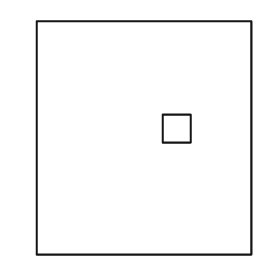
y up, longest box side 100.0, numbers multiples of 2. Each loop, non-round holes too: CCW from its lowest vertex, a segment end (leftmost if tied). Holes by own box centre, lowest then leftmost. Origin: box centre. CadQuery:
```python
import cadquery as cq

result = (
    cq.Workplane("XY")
    .moveTo(-46.0, -50.0)
    .lineTo(46.0, -50.0)
    .lineTo(46.0, 50.0)
    .lineTo(-46.0, 50.0)
    .close()
    .moveTo(8.0, -2.0)
    .lineTo(20.0, -2.0)
    .lineTo(20.0, 10.0)
    .lineTo(8.0, 10.0)
    .close()
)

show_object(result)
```